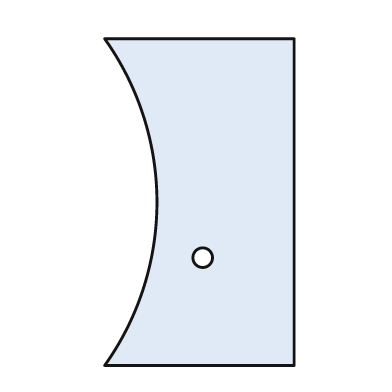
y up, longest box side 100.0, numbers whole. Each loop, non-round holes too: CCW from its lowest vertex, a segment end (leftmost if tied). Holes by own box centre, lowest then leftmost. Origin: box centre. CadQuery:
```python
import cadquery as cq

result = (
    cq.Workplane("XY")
    .moveTo(-29.0, -50.0)
    .lineTo(29.0, -50.0)
    .lineTo(29.0, 50.0)
    .lineTo(-29.0, 50.0)
    .threePointArc((-13.0, 0.0), (-29.0, -50.0))
    .close()
    .moveTo(1.0, -17.0)
    .circle(3.0)
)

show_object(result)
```